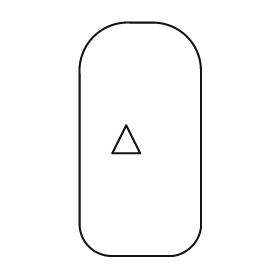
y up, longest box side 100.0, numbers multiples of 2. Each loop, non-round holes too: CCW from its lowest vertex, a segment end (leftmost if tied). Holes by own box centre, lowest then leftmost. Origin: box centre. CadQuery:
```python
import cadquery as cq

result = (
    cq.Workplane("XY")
    .moveTo(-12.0, -50.0)
    .lineTo(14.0, -50.0)
    .threePointArc((22.0, -46.0), (26.0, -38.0))
    .lineTo(26.0, 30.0)
    .threePointArc((20.0, 44.0), (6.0, 50.0))
    .lineTo(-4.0, 50.0)
    .threePointArc((-20.0, 44.0), (-26.0, 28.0))
    .lineTo(-26.0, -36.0)
    .threePointArc((-22.0, -46.0), (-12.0, -50.0))
    .close()
    .moveTo(-12.0, -6.0)
    .lineTo(0.0, -6.0)
    .lineTo(-6.0, 6.0)
    .close()
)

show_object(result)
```